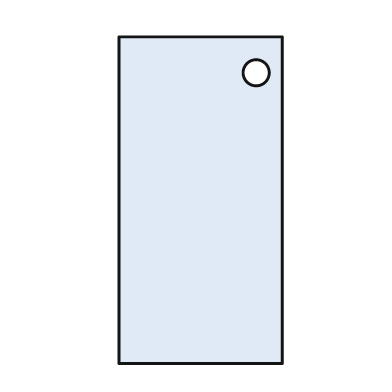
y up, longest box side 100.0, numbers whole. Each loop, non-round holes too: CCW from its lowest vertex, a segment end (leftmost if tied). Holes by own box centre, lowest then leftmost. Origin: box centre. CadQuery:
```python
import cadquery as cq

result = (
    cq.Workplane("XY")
    .moveTo(-25.0, -50.0)
    .lineTo(25.0, -50.0)
    .lineTo(25.0, 50.0)
    .lineTo(-25.0, 50.0)
    .close()
    .moveTo(17.0, 39.0)
    .circle(4.0)
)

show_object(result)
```